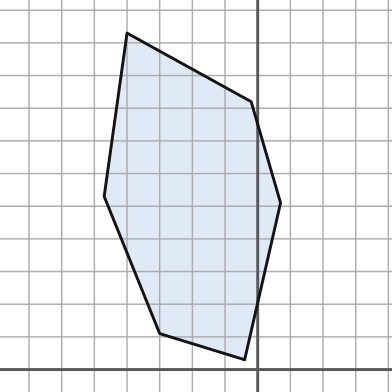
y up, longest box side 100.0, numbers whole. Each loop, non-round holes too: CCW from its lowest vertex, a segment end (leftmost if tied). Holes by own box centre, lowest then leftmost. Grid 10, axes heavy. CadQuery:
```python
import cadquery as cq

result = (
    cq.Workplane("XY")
    .moveTo(-4.0, 3.0)
    .lineTo(7.0, 51.0)
    .lineTo(-2.0, 82.0)
    .lineTo(-40.0, 103.0)
    .lineTo(-47.0, 53.0)
    .lineTo(-30.0, 11.0)
    .close()
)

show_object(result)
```